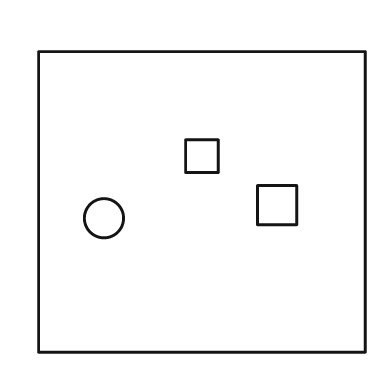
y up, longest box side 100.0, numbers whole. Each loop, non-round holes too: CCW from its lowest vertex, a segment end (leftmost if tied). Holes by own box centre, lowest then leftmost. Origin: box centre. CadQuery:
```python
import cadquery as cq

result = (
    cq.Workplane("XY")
    .moveTo(-50.0, -46.0)
    .lineTo(50.0, -46.0)
    .lineTo(50.0, 46.0)
    .lineTo(-50.0, 46.0)
    .close()
    .moveTo(-30.0, -5.0)
    .circle(6.0)
    .moveTo(17.0, -7.0)
    .lineTo(29.0, -7.0)
    .lineTo(29.0, 5.0)
    .lineTo(17.0, 5.0)
    .close()
    .moveTo(-5.0, 9.0)
    .lineTo(5.0, 9.0)
    .lineTo(5.0, 19.0)
    .lineTo(-5.0, 19.0)
    .close()
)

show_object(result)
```